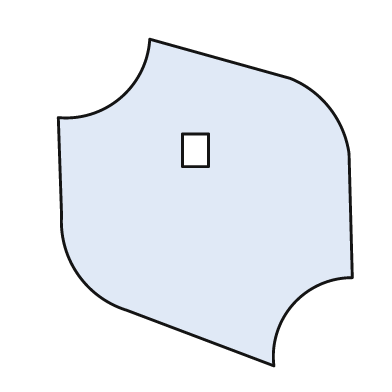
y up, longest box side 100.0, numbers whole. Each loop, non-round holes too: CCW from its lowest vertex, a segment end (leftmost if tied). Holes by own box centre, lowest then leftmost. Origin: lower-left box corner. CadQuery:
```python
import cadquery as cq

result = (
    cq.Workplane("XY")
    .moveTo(66.0, 0.0)
    .threePointArc((72.0, 19.0), (90.0, 27.0))
    .lineTo(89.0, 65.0)
    .threePointArc((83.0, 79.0), (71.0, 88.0))
    .lineTo(28.0, 100.0)
    .threePointArc((19.0, 82.0), (0.0, 76.0))
    .lineTo(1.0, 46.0)
    .threePointArc((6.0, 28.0), (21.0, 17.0))
    .close()
    .moveTo(38.0, 61.0)
    .lineTo(46.0, 61.0)
    .lineTo(46.0, 71.0)
    .lineTo(38.0, 71.0)
    .close()
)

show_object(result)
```